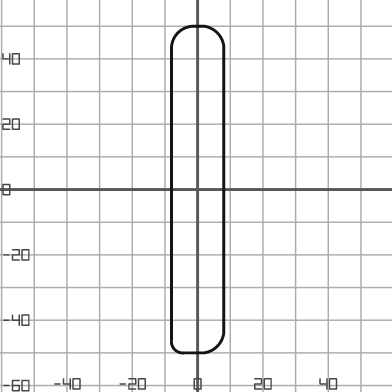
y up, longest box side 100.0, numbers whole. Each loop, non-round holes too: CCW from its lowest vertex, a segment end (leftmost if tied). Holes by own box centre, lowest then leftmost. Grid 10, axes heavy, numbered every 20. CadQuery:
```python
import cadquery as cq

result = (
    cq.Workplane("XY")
    .moveTo(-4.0, -50.0)
    .lineTo(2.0, -50.0)
    .threePointArc((6.0, -48.0), (8.0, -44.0))
    .lineTo(8.0, 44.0)
    .threePointArc((6.0, 48.0), (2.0, 50.0))
    .lineTo(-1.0, 50.0)
    .threePointArc((-6.0, 48.0), (-8.0, 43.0))
    .lineTo(-8.0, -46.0)
    .threePointArc((-7.0, -49.0), (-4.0, -50.0))
    .close()
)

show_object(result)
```